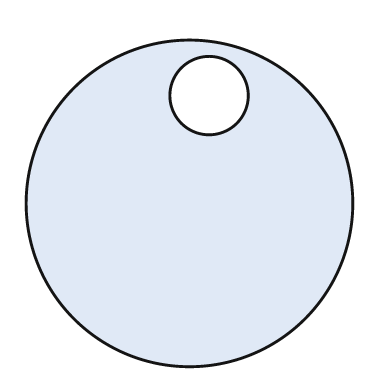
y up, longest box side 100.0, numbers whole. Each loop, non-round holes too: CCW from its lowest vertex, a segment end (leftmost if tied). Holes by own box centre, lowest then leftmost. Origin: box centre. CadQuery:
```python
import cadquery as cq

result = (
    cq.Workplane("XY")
    .moveTo(0.0, 0.0)
    .circle(50.0)
    .moveTo(6.0, 33.0)
    .circle(12.0)
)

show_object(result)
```